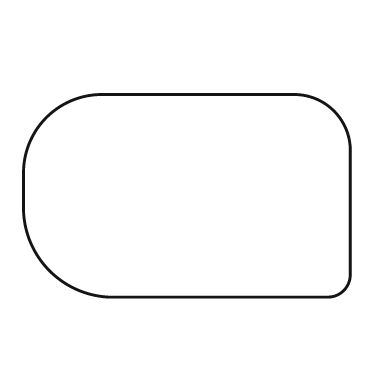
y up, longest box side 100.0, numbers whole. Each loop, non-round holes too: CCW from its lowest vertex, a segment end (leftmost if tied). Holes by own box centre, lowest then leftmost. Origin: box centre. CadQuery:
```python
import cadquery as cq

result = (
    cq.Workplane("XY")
    .moveTo(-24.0, -31.0)
    .lineTo(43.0, -31.0)
    .threePointArc((48.0, -29.0), (50.0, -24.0))
    .lineTo(50.0, 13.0)
    .threePointArc((45.0, 26.0), (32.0, 31.0))
    .lineTo(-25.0, 31.0)
    .threePointArc((-43.0, 24.0), (-50.0, 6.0))
    .lineTo(-50.0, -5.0)
    .threePointArc((-42.0, -23.0), (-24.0, -31.0))
    .close()
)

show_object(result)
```